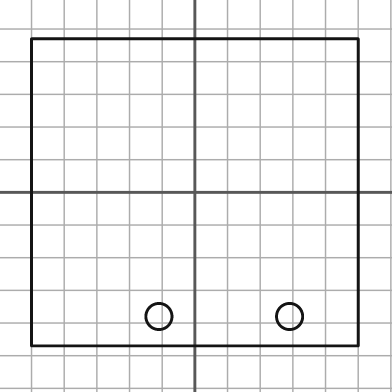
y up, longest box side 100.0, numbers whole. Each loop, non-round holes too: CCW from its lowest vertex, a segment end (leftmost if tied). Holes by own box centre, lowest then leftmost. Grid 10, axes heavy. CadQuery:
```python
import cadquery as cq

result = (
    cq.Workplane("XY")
    .moveTo(-50.0, -47.0)
    .lineTo(50.0, -47.0)
    .lineTo(50.0, 47.0)
    .lineTo(-50.0, 47.0)
    .close()
    .moveTo(-11.0, -38.0)
    .circle(4.0)
    .moveTo(29.0, -38.0)
    .circle(4.0)
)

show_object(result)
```